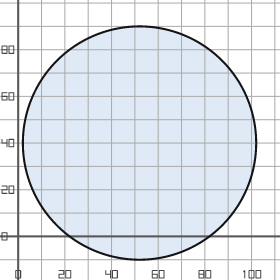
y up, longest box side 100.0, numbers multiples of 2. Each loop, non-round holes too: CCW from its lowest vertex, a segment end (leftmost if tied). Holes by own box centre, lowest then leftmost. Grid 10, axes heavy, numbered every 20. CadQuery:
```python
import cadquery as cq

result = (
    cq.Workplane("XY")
    .moveTo(52.0, 40.0)
    .circle(50.0)
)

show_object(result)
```